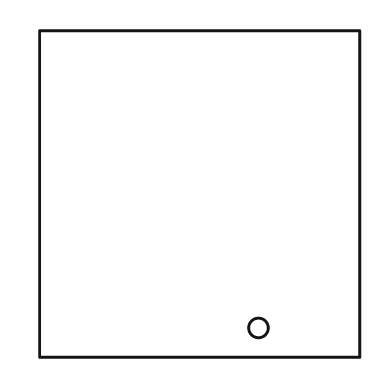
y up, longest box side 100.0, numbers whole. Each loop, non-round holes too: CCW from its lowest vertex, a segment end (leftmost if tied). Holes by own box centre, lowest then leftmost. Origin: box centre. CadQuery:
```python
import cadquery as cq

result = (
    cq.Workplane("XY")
    .moveTo(-49.0, -50.0)
    .lineTo(49.0, -50.0)
    .lineTo(49.0, 50.0)
    .lineTo(-49.0, 50.0)
    .close()
    .moveTo(18.0, -41.0)
    .circle(3.0)
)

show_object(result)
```